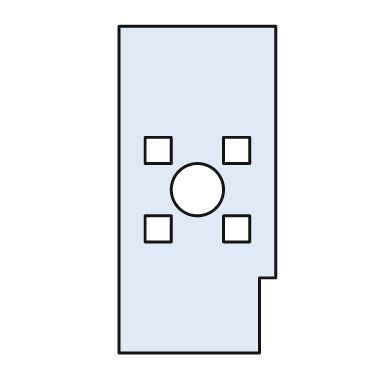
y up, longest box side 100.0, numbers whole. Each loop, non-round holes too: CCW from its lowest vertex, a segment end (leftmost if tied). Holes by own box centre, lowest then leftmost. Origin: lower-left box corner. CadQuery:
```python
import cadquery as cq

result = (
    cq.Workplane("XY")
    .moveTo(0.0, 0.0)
    .lineTo(43.0, 0.0)
    .lineTo(43.0, 23.0)
    .lineTo(48.0, 23.0)
    .lineTo(48.0, 100.0)
    .lineTo(0.0, 100.0)
    .close()
    .moveTo(8.0, 34.0)
    .lineTo(16.0, 34.0)
    .lineTo(16.0, 42.0)
    .lineTo(8.0, 42.0)
    .close()
    .moveTo(32.0, 34.0)
    .lineTo(40.0, 34.0)
    .lineTo(40.0, 42.0)
    .lineTo(32.0, 42.0)
    .close()
    .moveTo(24.0, 50.0)
    .circle(8.0)
    .moveTo(8.0, 58.0)
    .lineTo(16.0, 58.0)
    .lineTo(16.0, 66.0)
    .lineTo(8.0, 66.0)
    .close()
    .moveTo(32.0, 58.0)
    .lineTo(40.0, 58.0)
    .lineTo(40.0, 66.0)
    .lineTo(32.0, 66.0)
    .close()
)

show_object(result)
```